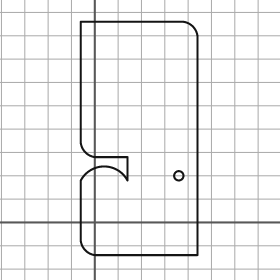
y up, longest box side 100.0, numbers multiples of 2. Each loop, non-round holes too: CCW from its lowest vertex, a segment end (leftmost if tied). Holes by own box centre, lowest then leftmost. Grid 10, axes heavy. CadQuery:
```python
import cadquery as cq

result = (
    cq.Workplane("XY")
    .moveTo(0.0, -14.0)
    .lineTo(44.0, -14.0)
    .lineTo(44.0, 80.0)
    .threePointArc((42.0, 84.0), (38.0, 86.0))
    .lineTo(-6.0, 86.0)
    .lineTo(-6.0, 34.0)
    .threePointArc((-4.0, 30.0), (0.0, 28.0))
    .lineTo(14.0, 28.0)
    .lineTo(14.0, 18.0)
    .threePointArc((4.0, 24.0), (-6.0, 18.0))
    .lineTo(-6.0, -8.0)
    .threePointArc((-4.0, -12.0), (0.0, -14.0))
    .close()
    .moveTo(36.0, 20.0)
    .circle(2.0)
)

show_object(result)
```